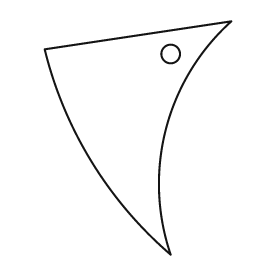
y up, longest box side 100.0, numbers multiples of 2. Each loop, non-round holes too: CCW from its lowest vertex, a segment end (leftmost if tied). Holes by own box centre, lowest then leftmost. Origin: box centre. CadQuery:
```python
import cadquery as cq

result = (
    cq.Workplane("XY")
    .moveTo(14.0, -50.0)
    .threePointArc((12.0, 4.0), (40.0, 50.0))
    .lineTo(-40.0, 38.0)
    .threePointArc((-20.0, -10.0), (14.0, -50.0))
    .close()
    .moveTo(14.0, 36.0)
    .circle(4.0)
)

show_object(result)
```